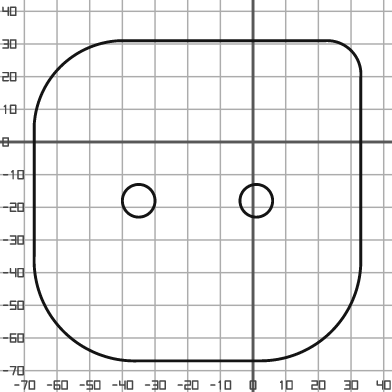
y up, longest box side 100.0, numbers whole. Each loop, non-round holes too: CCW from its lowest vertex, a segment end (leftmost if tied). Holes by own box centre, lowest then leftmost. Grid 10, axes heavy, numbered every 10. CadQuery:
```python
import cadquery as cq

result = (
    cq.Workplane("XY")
    .moveTo(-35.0, -67.0)
    .lineTo(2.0, -67.0)
    .threePointArc((24.0, -58.0), (33.0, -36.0))
    .lineTo(33.0, 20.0)
    .threePointArc((30.0, 28.0), (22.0, 31.0))
    .lineTo(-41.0, 31.0)
    .threePointArc((-59.0, 23.0), (-67.0, 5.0))
    .lineTo(-67.0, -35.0)
    .threePointArc((-58.0, -58.0), (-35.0, -67.0))
    .close()
    .moveTo(-35.0, -18.0)
    .circle(5.0)
    .moveTo(1.0, -18.0)
    .circle(5.0)
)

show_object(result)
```